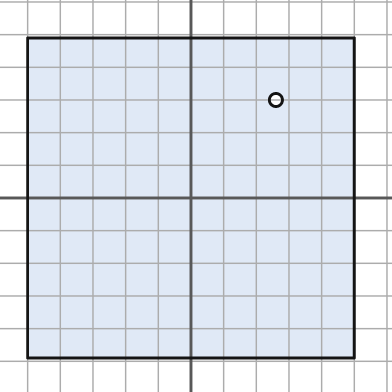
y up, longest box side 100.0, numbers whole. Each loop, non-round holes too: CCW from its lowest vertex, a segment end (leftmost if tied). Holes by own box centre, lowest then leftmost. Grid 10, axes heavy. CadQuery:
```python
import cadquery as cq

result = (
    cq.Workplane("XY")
    .moveTo(-50.0, -49.0)
    .lineTo(50.0, -49.0)
    .lineTo(50.0, 49.0)
    .lineTo(-50.0, 49.0)
    .close()
    .moveTo(26.0, 30.0)
    .circle(2.0)
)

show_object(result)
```